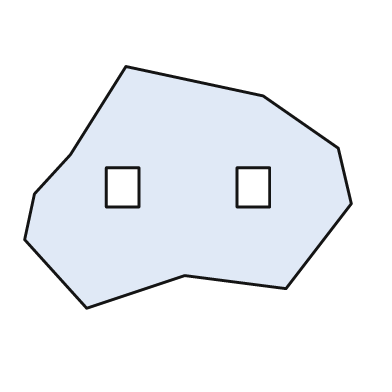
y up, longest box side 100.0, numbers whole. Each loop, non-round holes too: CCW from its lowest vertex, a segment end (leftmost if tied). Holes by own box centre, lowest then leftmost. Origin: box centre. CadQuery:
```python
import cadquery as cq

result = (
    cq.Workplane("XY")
    .moveTo(-31.0, -37.0)
    .lineTo(-1.0, -27.0)
    .lineTo(30.0, -31.0)
    .lineTo(50.0, -5.0)
    .lineTo(46.0, 12.0)
    .lineTo(23.0, 28.0)
    .lineTo(-19.0, 37.0)
    .lineTo(-36.0, 10.0)
    .lineTo(-47.0, -2.0)
    .lineTo(-50.0, -16.0)
    .close()
    .moveTo(-25.0, -6.0)
    .lineTo(-15.0, -6.0)
    .lineTo(-15.0, 6.0)
    .lineTo(-25.0, 6.0)
    .close()
    .moveTo(15.0, -6.0)
    .lineTo(25.0, -6.0)
    .lineTo(25.0, 6.0)
    .lineTo(15.0, 6.0)
    .close()
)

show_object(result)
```